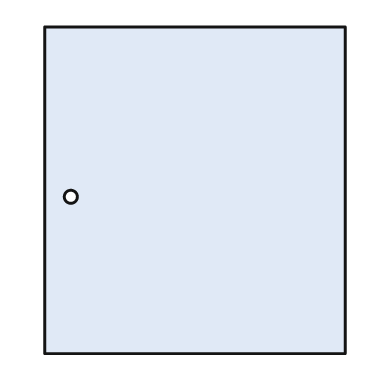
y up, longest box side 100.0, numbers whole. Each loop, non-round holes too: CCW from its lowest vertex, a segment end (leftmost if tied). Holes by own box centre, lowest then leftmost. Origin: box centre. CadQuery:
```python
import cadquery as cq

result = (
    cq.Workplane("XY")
    .moveTo(-46.0, -50.0)
    .lineTo(46.0, -50.0)
    .lineTo(46.0, 50.0)
    .lineTo(-46.0, 50.0)
    .close()
    .moveTo(-38.0, -2.0)
    .circle(2.0)
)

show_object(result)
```